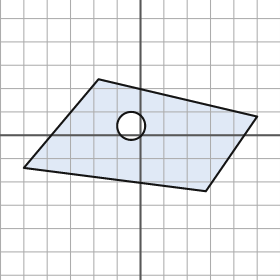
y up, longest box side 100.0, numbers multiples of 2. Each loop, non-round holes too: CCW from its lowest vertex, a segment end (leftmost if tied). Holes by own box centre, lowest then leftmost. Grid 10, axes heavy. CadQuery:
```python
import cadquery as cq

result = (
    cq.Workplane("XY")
    .moveTo(28.0, -24.0)
    .lineTo(50.0, 8.0)
    .lineTo(-18.0, 24.0)
    .lineTo(-50.0, -14.0)
    .close()
    .moveTo(-4.0, 4.0)
    .circle(6.0)
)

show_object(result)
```